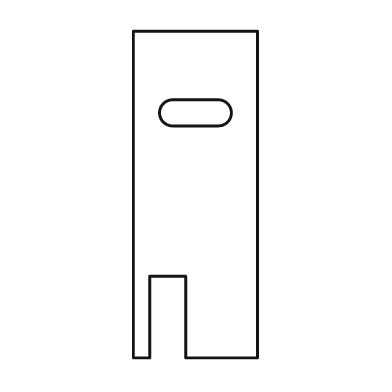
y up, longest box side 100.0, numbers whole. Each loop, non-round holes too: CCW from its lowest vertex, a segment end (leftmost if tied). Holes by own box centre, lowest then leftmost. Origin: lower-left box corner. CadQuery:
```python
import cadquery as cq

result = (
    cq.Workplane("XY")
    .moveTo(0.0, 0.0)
    .lineTo(5.0, 0.0)
    .lineTo(5.0, 25.0)
    .lineTo(16.0, 25.0)
    .lineTo(16.0, 0.0)
    .lineTo(38.0, 0.0)
    .lineTo(38.0, 100.0)
    .lineTo(0.0, 100.0)
    .close()
    .moveTo(12.0, 71.0)
    .lineTo(26.0, 71.0)
    .threePointArc((30.0, 75.0), (26.0, 79.0))
    .lineTo(12.0, 79.0)
    .threePointArc((8.0, 75.0), (12.0, 71.0))
    .close()
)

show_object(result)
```